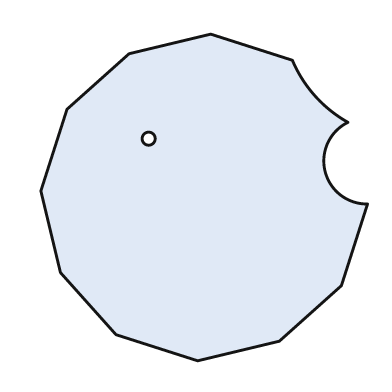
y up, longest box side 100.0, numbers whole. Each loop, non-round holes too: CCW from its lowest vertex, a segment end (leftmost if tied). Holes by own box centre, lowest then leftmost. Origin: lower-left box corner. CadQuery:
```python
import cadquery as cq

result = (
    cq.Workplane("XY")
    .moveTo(48.0, 0.0)
    .lineTo(73.0, 6.0)
    .lineTo(92.0, 23.0)
    .lineTo(100.0, 48.0)
    .threePointArc((87.0, 58.0), (94.0, 73.0))
    .threePointArc((84.0, 81.0), (77.0, 92.0))
    .lineTo(52.0, 100.0)
    .lineTo(27.0, 94.0)
    .lineTo(8.0, 77.0)
    .lineTo(0.0, 52.0)
    .lineTo(6.0, 27.0)
    .lineTo(23.0, 8.0)
    .close()
    .moveTo(33.0, 68.0)
    .circle(2.0)
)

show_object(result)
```